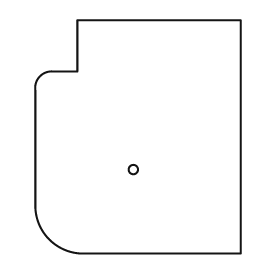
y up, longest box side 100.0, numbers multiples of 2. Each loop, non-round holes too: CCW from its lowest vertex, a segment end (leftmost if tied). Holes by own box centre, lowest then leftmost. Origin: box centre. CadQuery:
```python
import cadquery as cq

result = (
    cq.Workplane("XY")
    .moveTo(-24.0, -50.0)
    .lineTo(44.0, -50.0)
    .lineTo(44.0, 50.0)
    .lineTo(-26.0, 50.0)
    .lineTo(-26.0, 28.0)
    .lineTo(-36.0, 28.0)
    .threePointArc((-42.0, 26.0), (-44.0, 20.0))
    .lineTo(-44.0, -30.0)
    .threePointArc((-38.0, -44.0), (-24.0, -50.0))
    .close()
    .moveTo(-2.0, -14.0)
    .circle(2.0)
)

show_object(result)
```